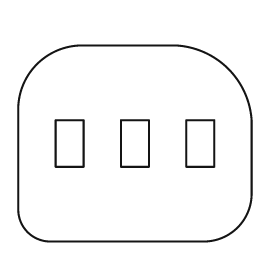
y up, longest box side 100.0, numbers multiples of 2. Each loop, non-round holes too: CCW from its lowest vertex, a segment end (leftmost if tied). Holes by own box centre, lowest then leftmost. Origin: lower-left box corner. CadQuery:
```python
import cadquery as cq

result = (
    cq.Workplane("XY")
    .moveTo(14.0, 0.0)
    .lineTo(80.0, 0.0)
    .threePointArc((94.0, 6.0), (100.0, 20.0))
    .lineTo(100.0, 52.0)
    .threePointArc((90.0, 74.0), (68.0, 84.0))
    .lineTo(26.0, 84.0)
    .threePointArc((8.0, 76.0), (0.0, 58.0))
    .lineTo(0.0, 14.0)
    .threePointArc((4.0, 4.0), (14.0, 0.0))
    .close()
    .moveTo(16.0, 32.0)
    .lineTo(28.0, 32.0)
    .lineTo(28.0, 52.0)
    .lineTo(16.0, 52.0)
    .close()
    .moveTo(44.0, 32.0)
    .lineTo(56.0, 32.0)
    .lineTo(56.0, 52.0)
    .lineTo(44.0, 52.0)
    .close()
    .moveTo(72.0, 32.0)
    .lineTo(84.0, 32.0)
    .lineTo(84.0, 52.0)
    .lineTo(72.0, 52.0)
    .close()
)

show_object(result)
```